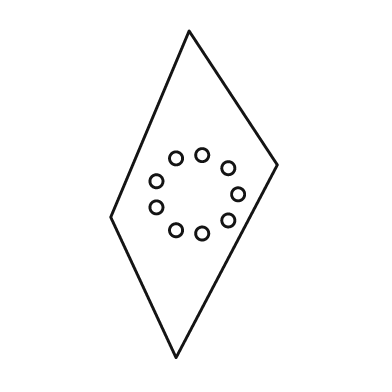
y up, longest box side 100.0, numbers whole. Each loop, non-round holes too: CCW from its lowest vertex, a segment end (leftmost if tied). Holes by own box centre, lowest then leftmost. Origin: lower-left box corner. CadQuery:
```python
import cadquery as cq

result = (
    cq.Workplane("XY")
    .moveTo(20.0, 0.0)
    .lineTo(51.0, 59.0)
    .lineTo(24.0, 100.0)
    .lineTo(0.0, 43.0)
    .close()
    .moveTo(28.0, 38.0)
    .circle(2.0)
    .moveTo(20.0, 39.0)
    .circle(2.0)
    .moveTo(36.0, 42.0)
    .circle(2.0)
    .moveTo(14.0, 46.0)
    .circle(2.0)
    .moveTo(39.0, 50.0)
    .circle(2.0)
    .moveTo(14.0, 54.0)
    .circle(2.0)
    .moveTo(36.0, 58.0)
    .circle(2.0)
    .moveTo(20.0, 61.0)
    .circle(2.0)
    .moveTo(28.0, 62.0)
    .circle(2.0)
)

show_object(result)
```